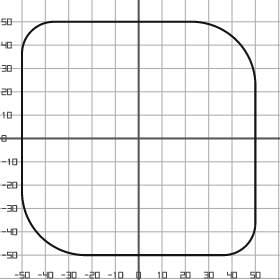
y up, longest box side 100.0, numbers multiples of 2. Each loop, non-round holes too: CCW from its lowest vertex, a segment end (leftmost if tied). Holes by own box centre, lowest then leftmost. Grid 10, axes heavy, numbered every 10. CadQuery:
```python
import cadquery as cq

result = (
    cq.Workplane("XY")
    .moveTo(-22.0, -50.0)
    .lineTo(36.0, -50.0)
    .threePointArc((46.0, -46.0), (50.0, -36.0))
    .lineTo(50.0, 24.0)
    .threePointArc((42.0, 42.0), (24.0, 50.0))
    .lineTo(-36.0, 50.0)
    .threePointArc((-46.0, 46.0), (-50.0, 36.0))
    .lineTo(-50.0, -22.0)
    .threePointArc((-42.0, -42.0), (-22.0, -50.0))
    .close()
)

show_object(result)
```